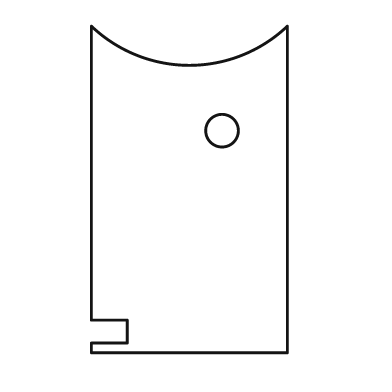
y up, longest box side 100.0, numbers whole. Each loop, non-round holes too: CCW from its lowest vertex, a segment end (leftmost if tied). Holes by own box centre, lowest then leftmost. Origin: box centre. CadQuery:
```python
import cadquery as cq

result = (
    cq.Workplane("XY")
    .moveTo(-30.0, -50.0)
    .lineTo(30.0, -50.0)
    .lineTo(30.0, 50.0)
    .threePointArc((0.0, 38.0), (-30.0, 50.0))
    .lineTo(-30.0, -40.0)
    .lineTo(-19.0, -40.0)
    .lineTo(-19.0, -47.0)
    .lineTo(-30.0, -47.0)
    .close()
    .moveTo(10.0, 18.0)
    .circle(5.0)
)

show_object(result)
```